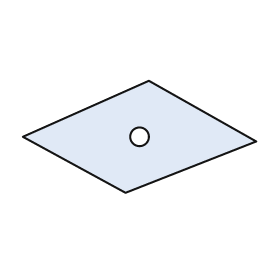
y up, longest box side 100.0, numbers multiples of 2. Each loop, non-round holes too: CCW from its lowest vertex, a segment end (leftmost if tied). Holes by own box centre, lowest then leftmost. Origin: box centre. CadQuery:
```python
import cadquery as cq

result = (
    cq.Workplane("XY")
    .moveTo(-6.0, -24.0)
    .lineTo(50.0, -2.0)
    .lineTo(4.0, 24.0)
    .lineTo(-50.0, 0.0)
    .close()
    .moveTo(0.0, 0.0)
    .circle(4.0)
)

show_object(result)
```